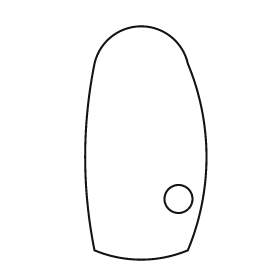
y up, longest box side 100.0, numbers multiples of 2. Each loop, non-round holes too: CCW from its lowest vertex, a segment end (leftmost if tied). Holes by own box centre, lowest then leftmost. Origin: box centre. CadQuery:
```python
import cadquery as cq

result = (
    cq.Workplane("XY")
    .moveTo(-22.0, -46.0)
    .threePointArc((-2.0, -50.0), (18.0, -46.0))
    .threePointArc((26.0, -6.0), (18.0, 34.0))
    .threePointArc((-2.0, 50.0), (-22.0, 34.0))
    .threePointArc((-26.0, -6.0), (-22.0, -46.0))
    .close()
    .moveTo(14.0, -24.0)
    .circle(6.0)
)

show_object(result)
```